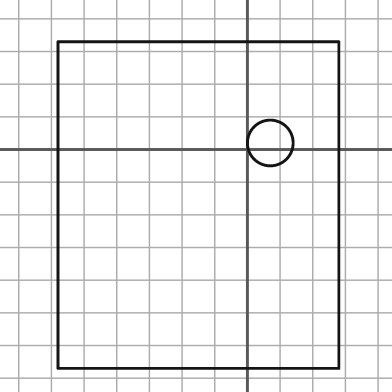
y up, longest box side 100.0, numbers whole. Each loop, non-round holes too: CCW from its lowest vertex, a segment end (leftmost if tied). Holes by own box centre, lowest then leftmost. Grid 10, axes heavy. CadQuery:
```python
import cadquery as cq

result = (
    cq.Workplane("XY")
    .moveTo(-58.0, -67.0)
    .lineTo(28.0, -67.0)
    .lineTo(28.0, 33.0)
    .lineTo(-58.0, 33.0)
    .close()
    .moveTo(7.0, 2.0)
    .circle(7.0)
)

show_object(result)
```